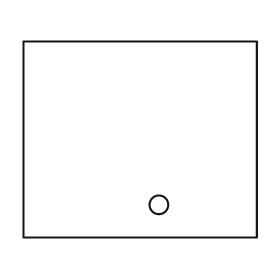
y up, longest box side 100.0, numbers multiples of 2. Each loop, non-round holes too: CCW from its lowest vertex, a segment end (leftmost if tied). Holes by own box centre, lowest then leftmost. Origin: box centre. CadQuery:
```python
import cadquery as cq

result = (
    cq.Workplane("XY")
    .moveTo(-50.0, -42.0)
    .lineTo(50.0, -42.0)
    .lineTo(50.0, 42.0)
    .lineTo(-50.0, 42.0)
    .close()
    .moveTo(8.0, -28.0)
    .circle(4.0)
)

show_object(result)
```